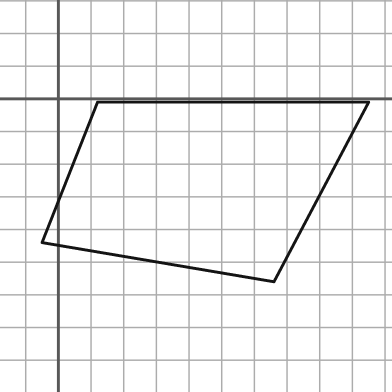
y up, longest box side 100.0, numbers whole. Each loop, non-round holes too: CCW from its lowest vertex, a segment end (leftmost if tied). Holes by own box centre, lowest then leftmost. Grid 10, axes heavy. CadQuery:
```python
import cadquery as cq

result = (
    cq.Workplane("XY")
    .moveTo(66.0, -56.0)
    .lineTo(95.0, -1.0)
    .lineTo(12.0, -1.0)
    .lineTo(-5.0, -44.0)
    .close()
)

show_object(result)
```